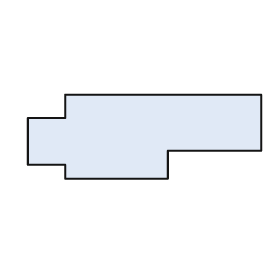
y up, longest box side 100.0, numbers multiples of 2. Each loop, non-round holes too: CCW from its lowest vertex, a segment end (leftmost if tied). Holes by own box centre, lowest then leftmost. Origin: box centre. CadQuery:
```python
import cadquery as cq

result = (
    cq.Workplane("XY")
    .moveTo(-34.0, -18.0)
    .lineTo(10.0, -18.0)
    .lineTo(10.0, -6.0)
    .lineTo(50.0, -6.0)
    .lineTo(50.0, 18.0)
    .lineTo(-34.0, 18.0)
    .lineTo(-34.0, 8.0)
    .lineTo(-50.0, 8.0)
    .lineTo(-50.0, -12.0)
    .lineTo(-34.0, -12.0)
    .close()
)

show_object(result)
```